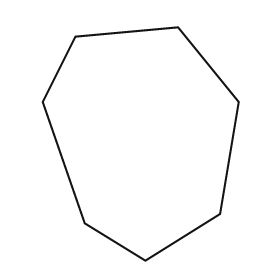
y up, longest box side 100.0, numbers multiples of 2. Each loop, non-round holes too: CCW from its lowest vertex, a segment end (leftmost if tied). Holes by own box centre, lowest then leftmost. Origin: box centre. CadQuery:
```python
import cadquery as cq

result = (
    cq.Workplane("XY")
    .moveTo(2.0, -50.0)
    .lineTo(34.0, -30.0)
    .lineTo(42.0, 18.0)
    .lineTo(16.0, 50.0)
    .lineTo(-28.0, 46.0)
    .lineTo(-42.0, 18.0)
    .lineTo(-24.0, -34.0)
    .close()
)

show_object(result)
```